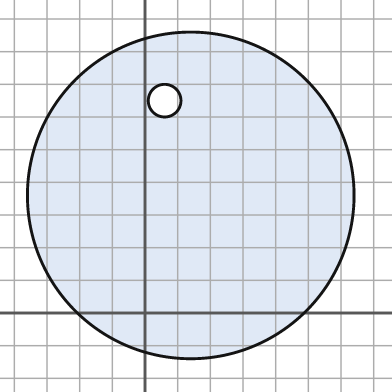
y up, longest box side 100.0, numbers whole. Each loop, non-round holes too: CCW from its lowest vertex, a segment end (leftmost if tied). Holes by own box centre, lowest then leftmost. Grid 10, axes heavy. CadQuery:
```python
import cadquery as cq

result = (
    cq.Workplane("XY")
    .moveTo(14.0, 36.0)
    .circle(50.0)
    .moveTo(6.0, 65.0)
    .circle(5.0)
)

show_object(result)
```